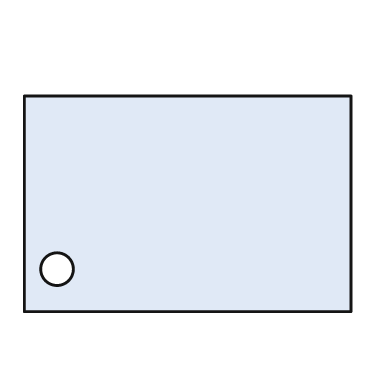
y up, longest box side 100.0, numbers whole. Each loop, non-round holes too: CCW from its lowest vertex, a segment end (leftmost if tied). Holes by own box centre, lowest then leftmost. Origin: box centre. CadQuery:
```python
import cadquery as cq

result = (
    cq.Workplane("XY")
    .moveTo(-50.0, -33.0)
    .lineTo(50.0, -33.0)
    .lineTo(50.0, 33.0)
    .lineTo(-50.0, 33.0)
    .close()
    .moveTo(-40.0, -20.0)
    .circle(5.0)
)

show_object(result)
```